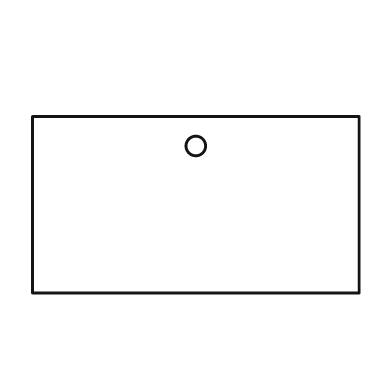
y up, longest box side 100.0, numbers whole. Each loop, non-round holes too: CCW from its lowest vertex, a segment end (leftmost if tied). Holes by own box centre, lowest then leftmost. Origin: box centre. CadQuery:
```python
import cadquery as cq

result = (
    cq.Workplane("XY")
    .moveTo(-50.0, -27.0)
    .lineTo(50.0, -27.0)
    .lineTo(50.0, 27.0)
    .lineTo(-50.0, 27.0)
    .close()
    .moveTo(0.0, 18.0)
    .circle(3.0)
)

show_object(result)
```